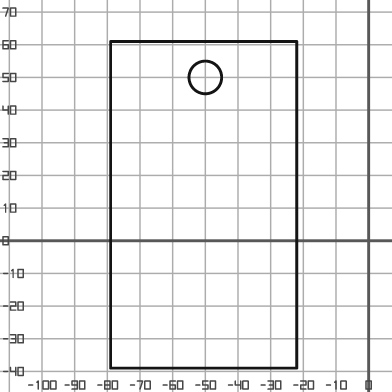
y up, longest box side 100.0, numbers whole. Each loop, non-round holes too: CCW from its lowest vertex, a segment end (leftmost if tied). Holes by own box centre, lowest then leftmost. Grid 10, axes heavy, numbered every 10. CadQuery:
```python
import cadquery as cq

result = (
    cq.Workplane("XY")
    .moveTo(-79.0, -39.0)
    .lineTo(-22.0, -39.0)
    .lineTo(-22.0, 61.0)
    .lineTo(-79.0, 61.0)
    .close()
    .moveTo(-50.0, 50.0)
    .circle(5.0)
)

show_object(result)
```